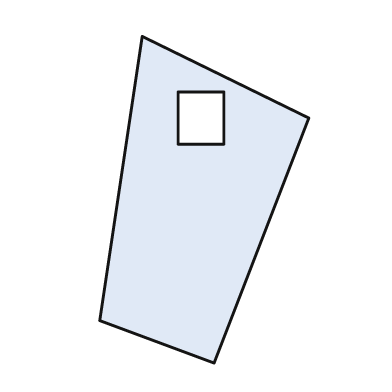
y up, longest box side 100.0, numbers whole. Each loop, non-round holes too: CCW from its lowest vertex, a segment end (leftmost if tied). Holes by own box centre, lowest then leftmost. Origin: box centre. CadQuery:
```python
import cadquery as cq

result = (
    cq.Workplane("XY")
    .moveTo(3.0, -50.0)
    .lineTo(32.0, 25.0)
    .lineTo(-19.0, 50.0)
    .lineTo(-32.0, -37.0)
    .close()
    .moveTo(-8.0, 17.0)
    .lineTo(6.0, 17.0)
    .lineTo(6.0, 33.0)
    .lineTo(-8.0, 33.0)
    .close()
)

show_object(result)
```